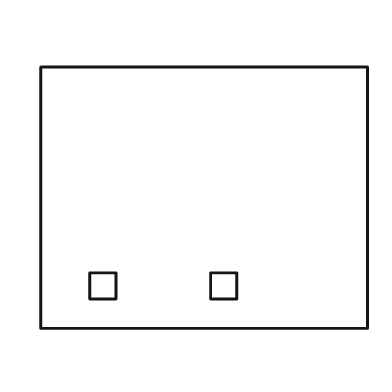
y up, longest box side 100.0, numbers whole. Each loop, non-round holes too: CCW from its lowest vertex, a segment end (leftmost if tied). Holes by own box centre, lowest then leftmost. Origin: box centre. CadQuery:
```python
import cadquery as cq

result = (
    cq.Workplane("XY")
    .moveTo(-50.0, -40.0)
    .lineTo(50.0, -40.0)
    .lineTo(50.0, 40.0)
    .lineTo(-50.0, 40.0)
    .close()
    .moveTo(-35.0, -31.0)
    .lineTo(-27.0, -31.0)
    .lineTo(-27.0, -23.0)
    .lineTo(-35.0, -23.0)
    .close()
    .moveTo(2.0, -31.0)
    .lineTo(10.0, -31.0)
    .lineTo(10.0, -23.0)
    .lineTo(2.0, -23.0)
    .close()
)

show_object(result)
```